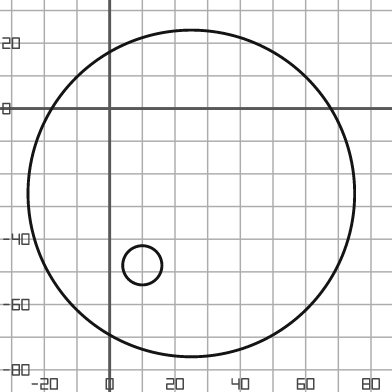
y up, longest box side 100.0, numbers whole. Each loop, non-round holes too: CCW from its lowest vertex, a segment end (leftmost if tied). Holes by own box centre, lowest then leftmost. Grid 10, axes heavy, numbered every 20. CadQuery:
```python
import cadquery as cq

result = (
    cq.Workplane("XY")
    .moveTo(25.0, -26.0)
    .circle(50.0)
    .moveTo(10.0, -48.0)
    .circle(6.0)
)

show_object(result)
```